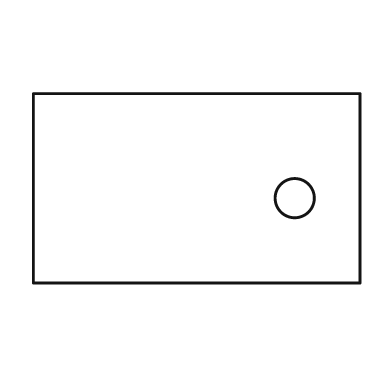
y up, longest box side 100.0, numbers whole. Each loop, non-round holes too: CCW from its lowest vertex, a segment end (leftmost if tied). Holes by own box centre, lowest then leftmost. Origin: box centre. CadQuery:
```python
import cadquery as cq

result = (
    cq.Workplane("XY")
    .moveTo(-50.0, -29.0)
    .lineTo(50.0, -29.0)
    .lineTo(50.0, 29.0)
    .lineTo(-50.0, 29.0)
    .close()
    .moveTo(30.0, -3.0)
    .circle(6.0)
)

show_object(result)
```